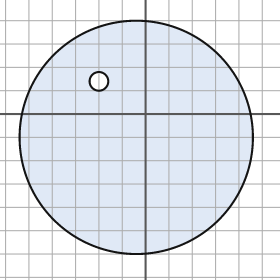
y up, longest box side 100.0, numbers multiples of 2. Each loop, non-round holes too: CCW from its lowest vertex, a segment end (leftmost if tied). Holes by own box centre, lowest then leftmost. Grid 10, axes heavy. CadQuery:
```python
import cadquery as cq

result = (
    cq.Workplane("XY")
    .moveTo(-4.0, -10.0)
    .circle(50.0)
    .moveTo(-20.0, 14.0)
    .circle(4.0)
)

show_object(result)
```